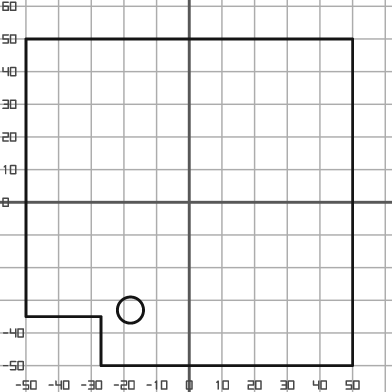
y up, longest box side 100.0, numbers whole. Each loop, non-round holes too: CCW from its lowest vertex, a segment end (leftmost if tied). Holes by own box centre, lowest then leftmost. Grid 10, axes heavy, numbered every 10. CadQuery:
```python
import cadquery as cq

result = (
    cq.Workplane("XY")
    .moveTo(-27.0, -50.0)
    .lineTo(50.0, -50.0)
    .lineTo(50.0, 50.0)
    .lineTo(-50.0, 50.0)
    .lineTo(-50.0, -35.0)
    .lineTo(-27.0, -35.0)
    .close()
    .moveTo(-18.0, -33.0)
    .circle(4.0)
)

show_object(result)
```